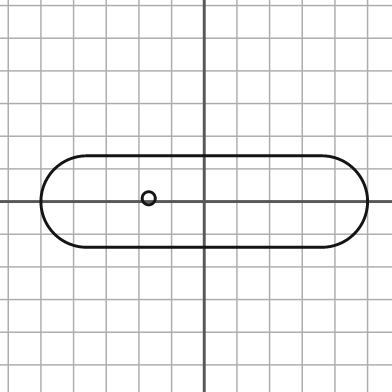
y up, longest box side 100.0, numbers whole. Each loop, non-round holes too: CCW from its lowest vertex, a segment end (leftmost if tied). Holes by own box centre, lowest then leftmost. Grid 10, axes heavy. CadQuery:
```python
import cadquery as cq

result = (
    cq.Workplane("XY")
    .moveTo(-36.0, -14.0)
    .lineTo(36.0, -14.0)
    .threePointArc((50.0, 0.0), (36.0, 14.0))
    .lineTo(-36.0, 14.0)
    .threePointArc((-50.0, 0.0), (-36.0, -14.0))
    .close()
    .moveTo(-17.0, 1.0)
    .circle(2.0)
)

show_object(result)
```